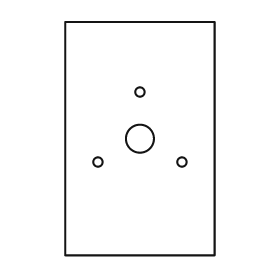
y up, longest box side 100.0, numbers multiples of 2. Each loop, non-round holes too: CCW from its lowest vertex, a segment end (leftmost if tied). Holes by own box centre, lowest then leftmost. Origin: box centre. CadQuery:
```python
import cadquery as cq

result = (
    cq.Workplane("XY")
    .moveTo(-32.0, -50.0)
    .lineTo(32.0, -50.0)
    .lineTo(32.0, 50.0)
    .lineTo(-32.0, 50.0)
    .close()
    .moveTo(-18.0, -10.0)
    .circle(2.0)
    .moveTo(18.0, -10.0)
    .circle(2.0)
    .moveTo(0.0, 0.0)
    .circle(6.0)
    .moveTo(0.0, 20.0)
    .circle(2.0)
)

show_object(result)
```